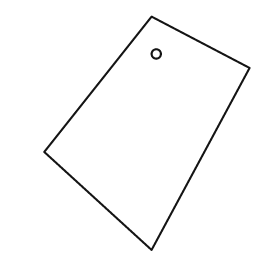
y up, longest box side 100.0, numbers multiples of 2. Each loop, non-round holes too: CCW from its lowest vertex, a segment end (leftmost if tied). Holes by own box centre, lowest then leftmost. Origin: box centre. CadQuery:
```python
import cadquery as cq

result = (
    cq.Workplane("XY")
    .moveTo(2.0, -50.0)
    .lineTo(44.0, 28.0)
    .lineTo(2.0, 50.0)
    .lineTo(-44.0, -8.0)
    .close()
    .moveTo(4.0, 34.0)
    .circle(2.0)
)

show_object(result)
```